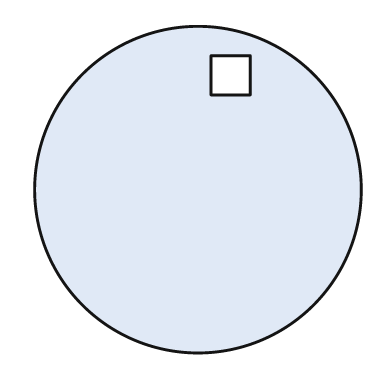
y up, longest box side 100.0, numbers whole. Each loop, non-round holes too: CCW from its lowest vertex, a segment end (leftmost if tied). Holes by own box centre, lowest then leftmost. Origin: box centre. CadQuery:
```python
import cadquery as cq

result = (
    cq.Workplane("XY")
    .moveTo(0.0, 0.0)
    .circle(50.0)
    .moveTo(4.0, 29.0)
    .lineTo(16.0, 29.0)
    .lineTo(16.0, 41.0)
    .lineTo(4.0, 41.0)
    .close()
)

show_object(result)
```